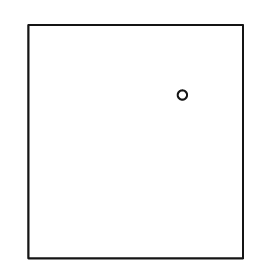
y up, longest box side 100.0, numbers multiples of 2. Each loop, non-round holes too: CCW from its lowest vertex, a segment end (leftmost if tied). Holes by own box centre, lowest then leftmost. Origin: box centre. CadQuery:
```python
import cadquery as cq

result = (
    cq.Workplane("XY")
    .moveTo(-46.0, -50.0)
    .lineTo(46.0, -50.0)
    .lineTo(46.0, 50.0)
    .lineTo(-46.0, 50.0)
    .close()
    .moveTo(20.0, 20.0)
    .circle(2.0)
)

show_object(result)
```